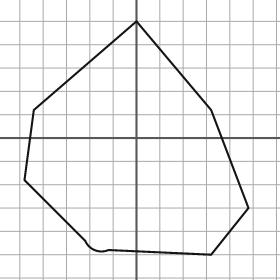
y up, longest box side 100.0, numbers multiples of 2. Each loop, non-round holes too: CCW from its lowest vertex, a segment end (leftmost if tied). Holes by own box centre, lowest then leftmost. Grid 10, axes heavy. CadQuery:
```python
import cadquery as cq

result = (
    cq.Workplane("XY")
    .moveTo(32.0, -50.0)
    .lineTo(48.0, -30.0)
    .lineTo(32.0, 12.0)
    .lineTo(0.0, 50.0)
    .lineTo(-44.0, 12.0)
    .lineTo(-48.0, -18.0)
    .lineTo(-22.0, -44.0)
    .threePointArc((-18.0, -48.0), (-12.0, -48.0))
    .close()
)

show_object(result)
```